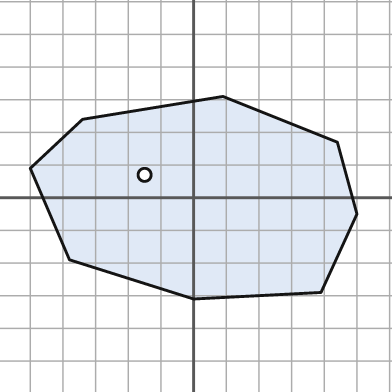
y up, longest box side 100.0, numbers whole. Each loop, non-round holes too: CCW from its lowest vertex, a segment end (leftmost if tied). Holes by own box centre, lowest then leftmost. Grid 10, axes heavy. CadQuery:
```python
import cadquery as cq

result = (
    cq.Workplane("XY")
    .moveTo(0.0, -31.0)
    .lineTo(39.0, -29.0)
    .lineTo(50.0, -5.0)
    .lineTo(44.0, 17.0)
    .lineTo(9.0, 31.0)
    .lineTo(-34.0, 24.0)
    .lineTo(-50.0, 9.0)
    .lineTo(-38.0, -19.0)
    .close()
    .moveTo(-15.0, 7.0)
    .circle(2.0)
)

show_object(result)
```